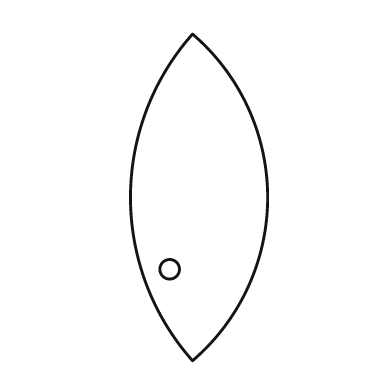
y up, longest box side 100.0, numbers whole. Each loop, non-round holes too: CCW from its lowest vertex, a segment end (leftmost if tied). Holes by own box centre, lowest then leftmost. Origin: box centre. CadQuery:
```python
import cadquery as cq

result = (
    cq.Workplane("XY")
    .moveTo(-2.0, -50.0)
    .threePointArc((21.0, 0.0), (-2.0, 50.0))
    .threePointArc((-21.0, 0.0), (-2.0, -50.0))
    .close()
    .moveTo(-9.0, -22.0)
    .circle(3.0)
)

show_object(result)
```